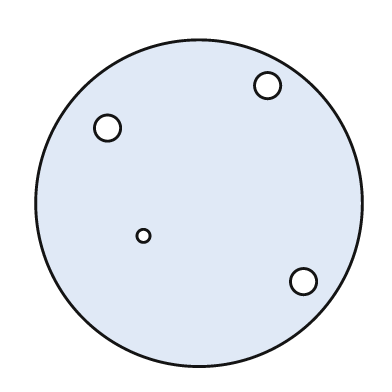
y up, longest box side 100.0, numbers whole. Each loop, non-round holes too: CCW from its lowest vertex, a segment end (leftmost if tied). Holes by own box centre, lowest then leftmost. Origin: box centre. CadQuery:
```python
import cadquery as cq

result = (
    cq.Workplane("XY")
    .moveTo(0.0, 0.0)
    .circle(50.0)
    .moveTo(32.0, -24.0)
    .circle(4.0)
    .moveTo(-17.0, -10.0)
    .circle(2.0)
    .moveTo(-28.0, 23.0)
    .circle(4.0)
    .moveTo(21.0, 36.0)
    .circle(4.0)
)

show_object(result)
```